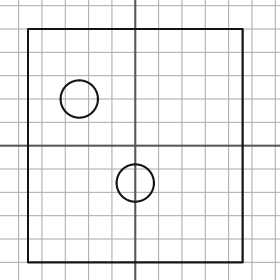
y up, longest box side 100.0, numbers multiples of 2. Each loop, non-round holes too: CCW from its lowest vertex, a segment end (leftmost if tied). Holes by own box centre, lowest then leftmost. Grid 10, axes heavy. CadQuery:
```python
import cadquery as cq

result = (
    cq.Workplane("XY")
    .moveTo(-46.0, -50.0)
    .lineTo(46.0, -50.0)
    .lineTo(46.0, 50.0)
    .lineTo(-46.0, 50.0)
    .close()
    .moveTo(0.0, -16.0)
    .circle(8.0)
    .moveTo(-24.0, 20.0)
    .circle(8.0)
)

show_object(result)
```